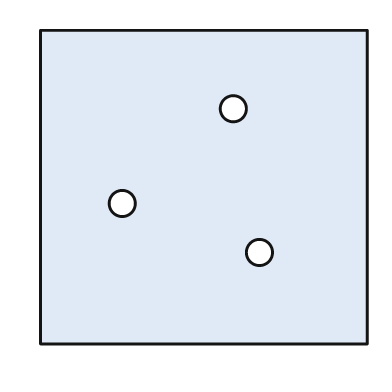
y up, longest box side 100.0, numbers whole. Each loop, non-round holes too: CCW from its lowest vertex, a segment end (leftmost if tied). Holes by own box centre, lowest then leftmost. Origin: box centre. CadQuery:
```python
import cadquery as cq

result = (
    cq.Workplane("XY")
    .moveTo(-50.0, -48.0)
    .lineTo(50.0, -48.0)
    .lineTo(50.0, 48.0)
    .lineTo(-50.0, 48.0)
    .close()
    .moveTo(17.0, -20.0)
    .circle(4.0)
    .moveTo(-25.0, -5.0)
    .circle(4.0)
    .moveTo(9.0, 24.0)
    .circle(4.0)
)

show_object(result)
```